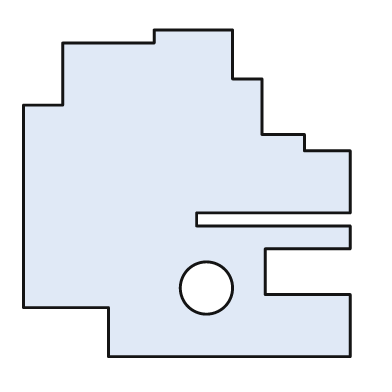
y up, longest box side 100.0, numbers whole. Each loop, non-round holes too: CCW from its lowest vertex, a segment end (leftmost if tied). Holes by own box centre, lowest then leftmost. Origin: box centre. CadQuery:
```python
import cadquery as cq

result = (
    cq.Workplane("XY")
    .moveTo(-24.0, -50.0)
    .lineTo(50.0, -50.0)
    .lineTo(50.0, -31.0)
    .lineTo(24.0, -31.0)
    .lineTo(24.0, -17.0)
    .lineTo(50.0, -17.0)
    .lineTo(50.0, -10.0)
    .lineTo(3.0, -10.0)
    .lineTo(3.0, -6.0)
    .lineTo(50.0, -6.0)
    .lineTo(50.0, 13.0)
    .lineTo(36.0, 13.0)
    .lineTo(36.0, 18.0)
    .lineTo(23.0, 18.0)
    .lineTo(23.0, 35.0)
    .lineTo(14.0, 35.0)
    .lineTo(14.0, 50.0)
    .lineTo(-10.0, 50.0)
    .lineTo(-10.0, 46.0)
    .lineTo(-38.0, 46.0)
    .lineTo(-38.0, 27.0)
    .lineTo(-50.0, 27.0)
    .lineTo(-50.0, -35.0)
    .lineTo(-24.0, -35.0)
    .close()
    .moveTo(6.0, -29.0)
    .circle(8.0)
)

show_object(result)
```